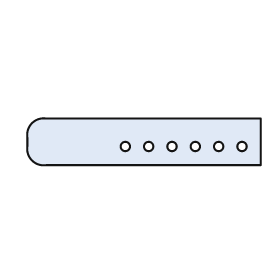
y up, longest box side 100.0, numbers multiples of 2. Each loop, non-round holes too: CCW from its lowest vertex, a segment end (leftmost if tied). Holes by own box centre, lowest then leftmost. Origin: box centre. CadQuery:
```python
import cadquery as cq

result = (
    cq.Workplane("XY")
    .moveTo(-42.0, -10.0)
    .lineTo(50.0, -10.0)
    .lineTo(50.0, 10.0)
    .lineTo(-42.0, 10.0)
    .threePointArc((-48.0, 8.0), (-50.0, 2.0))
    .lineTo(-50.0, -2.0)
    .threePointArc((-48.0, -8.0), (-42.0, -10.0))
    .close()
    .moveTo(-8.0, -2.0)
    .circle(2.0)
    .moveTo(2.0, -2.0)
    .circle(2.0)
    .moveTo(12.0, -2.0)
    .circle(2.0)
    .moveTo(22.0, -2.0)
    .circle(2.0)
    .moveTo(32.0, -2.0)
    .circle(2.0)
    .moveTo(42.0, -2.0)
    .circle(2.0)
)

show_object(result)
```